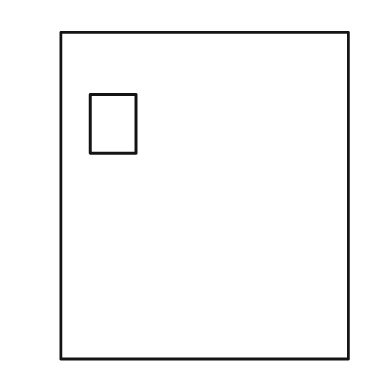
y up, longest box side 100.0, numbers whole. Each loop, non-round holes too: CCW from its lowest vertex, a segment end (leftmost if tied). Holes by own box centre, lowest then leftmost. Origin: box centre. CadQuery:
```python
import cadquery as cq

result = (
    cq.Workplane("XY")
    .moveTo(-44.0, -50.0)
    .lineTo(44.0, -50.0)
    .lineTo(44.0, 50.0)
    .lineTo(-44.0, 50.0)
    .close()
    .moveTo(-35.0, 13.0)
    .lineTo(-21.0, 13.0)
    .lineTo(-21.0, 31.0)
    .lineTo(-35.0, 31.0)
    .close()
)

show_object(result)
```